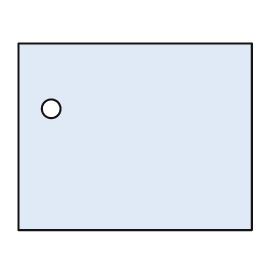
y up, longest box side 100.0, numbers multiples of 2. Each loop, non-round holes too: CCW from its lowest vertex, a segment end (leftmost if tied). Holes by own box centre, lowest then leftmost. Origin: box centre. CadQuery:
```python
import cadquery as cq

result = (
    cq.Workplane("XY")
    .moveTo(-50.0, -40.0)
    .lineTo(50.0, -40.0)
    .lineTo(50.0, 40.0)
    .lineTo(-50.0, 40.0)
    .close()
    .moveTo(-36.0, 12.0)
    .circle(4.0)
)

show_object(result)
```